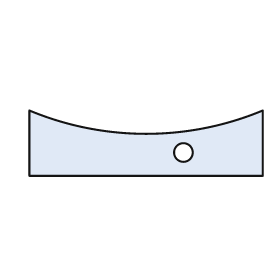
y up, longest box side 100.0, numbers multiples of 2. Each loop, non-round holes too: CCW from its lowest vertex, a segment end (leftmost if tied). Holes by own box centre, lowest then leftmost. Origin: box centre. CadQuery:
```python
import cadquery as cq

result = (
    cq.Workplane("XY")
    .moveTo(-50.0, -14.0)
    .lineTo(50.0, -14.0)
    .lineTo(50.0, 14.0)
    .threePointArc((0.0, 4.0), (-50.0, 14.0))
    .close()
    .moveTo(16.0, -4.0)
    .circle(4.0)
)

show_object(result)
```